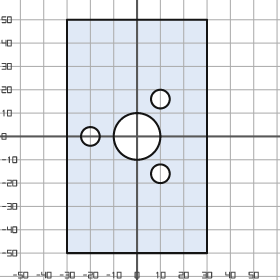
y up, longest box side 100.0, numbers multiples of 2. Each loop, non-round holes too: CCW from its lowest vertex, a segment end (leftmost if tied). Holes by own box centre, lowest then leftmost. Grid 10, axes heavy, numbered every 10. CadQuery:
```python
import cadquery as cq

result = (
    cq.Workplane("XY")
    .moveTo(-30.0, -50.0)
    .lineTo(30.0, -50.0)
    .lineTo(30.0, 50.0)
    .lineTo(-30.0, 50.0)
    .close()
    .moveTo(10.0, -16.0)
    .circle(4.0)
    .moveTo(-20.0, 0.0)
    .circle(4.0)
    .moveTo(0.0, 0.0)
    .circle(10.0)
    .moveTo(10.0, 16.0)
    .circle(4.0)
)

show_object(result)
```